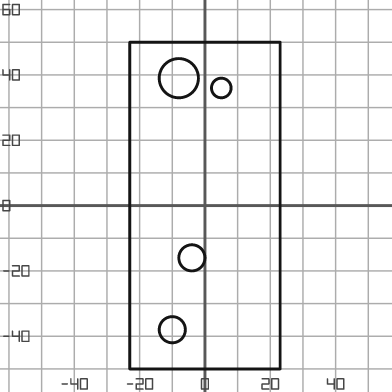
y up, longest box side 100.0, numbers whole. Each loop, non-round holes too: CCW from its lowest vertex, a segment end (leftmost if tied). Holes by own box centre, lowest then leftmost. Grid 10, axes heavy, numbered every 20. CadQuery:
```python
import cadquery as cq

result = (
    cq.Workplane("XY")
    .moveTo(-23.0, -50.0)
    .lineTo(23.0, -50.0)
    .lineTo(23.0, 50.0)
    .lineTo(-23.0, 50.0)
    .close()
    .moveTo(-10.0, -38.0)
    .circle(4.0)
    .moveTo(-4.0, -16.0)
    .circle(4.0)
    .moveTo(5.0, 36.0)
    .circle(3.0)
    .moveTo(-8.0, 39.0)
    .circle(6.0)
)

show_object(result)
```